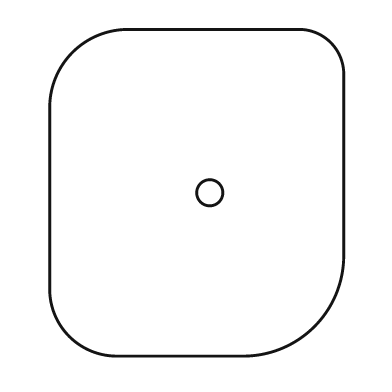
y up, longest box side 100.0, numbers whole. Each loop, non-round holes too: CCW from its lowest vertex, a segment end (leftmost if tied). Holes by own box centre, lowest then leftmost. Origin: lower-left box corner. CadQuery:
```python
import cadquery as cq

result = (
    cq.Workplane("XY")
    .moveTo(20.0, 0.0)
    .lineTo(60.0, 0.0)
    .threePointArc((81.0, 9.0), (90.0, 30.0))
    .lineTo(90.0, 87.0)
    .threePointArc((86.0, 96.0), (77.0, 100.0))
    .lineTo(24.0, 100.0)
    .threePointArc((7.0, 93.0), (0.0, 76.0))
    .lineTo(0.0, 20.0)
    .threePointArc((6.0, 6.0), (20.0, 0.0))
    .close()
    .moveTo(49.0, 50.0)
    .circle(4.0)
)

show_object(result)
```